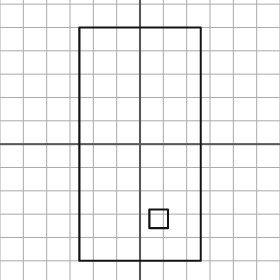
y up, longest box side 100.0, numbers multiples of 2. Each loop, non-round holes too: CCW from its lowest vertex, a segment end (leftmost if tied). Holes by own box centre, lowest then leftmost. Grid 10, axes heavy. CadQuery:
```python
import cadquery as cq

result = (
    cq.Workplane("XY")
    .moveTo(-26.0, -50.0)
    .lineTo(26.0, -50.0)
    .lineTo(26.0, 50.0)
    .lineTo(-26.0, 50.0)
    .close()
    .moveTo(4.0, -36.0)
    .lineTo(12.0, -36.0)
    .lineTo(12.0, -28.0)
    .lineTo(4.0, -28.0)
    .close()
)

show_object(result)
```